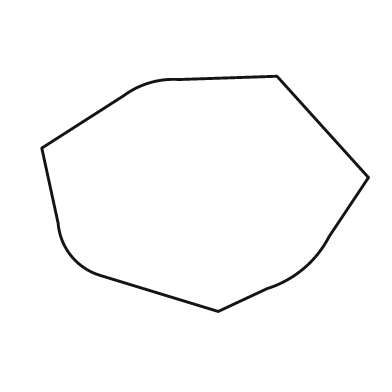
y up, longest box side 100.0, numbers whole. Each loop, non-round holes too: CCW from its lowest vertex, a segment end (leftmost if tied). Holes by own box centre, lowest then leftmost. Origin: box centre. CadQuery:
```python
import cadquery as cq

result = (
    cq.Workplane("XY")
    .moveTo(4.0, -36.0)
    .lineTo(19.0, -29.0)
    .threePointArc((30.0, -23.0), (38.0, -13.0))
    .lineTo(50.0, 5.0)
    .lineTo(22.0, 36.0)
    .lineTo(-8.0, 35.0)
    .threePointArc((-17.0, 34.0), (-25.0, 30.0))
    .lineTo(-50.0, 14.0)
    .lineTo(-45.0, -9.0)
    .threePointArc((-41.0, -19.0), (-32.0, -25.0))
    .close()
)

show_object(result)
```